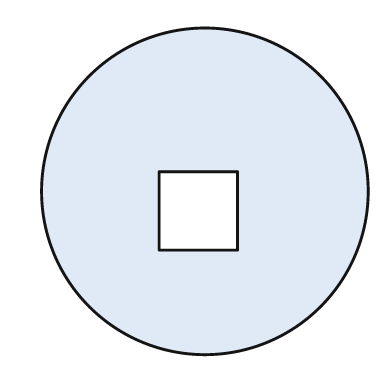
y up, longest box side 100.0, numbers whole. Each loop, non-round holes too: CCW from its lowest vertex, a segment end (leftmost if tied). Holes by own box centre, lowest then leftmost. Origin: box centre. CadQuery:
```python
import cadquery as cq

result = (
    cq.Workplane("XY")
    .moveTo(0.0, 0.0)
    .circle(50.0)
    .moveTo(-14.0, -18.0)
    .lineTo(10.0, -18.0)
    .lineTo(10.0, 6.0)
    .lineTo(-14.0, 6.0)
    .close()
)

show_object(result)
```